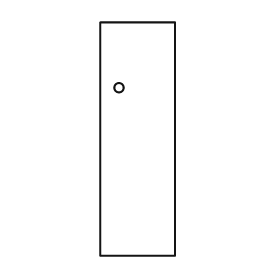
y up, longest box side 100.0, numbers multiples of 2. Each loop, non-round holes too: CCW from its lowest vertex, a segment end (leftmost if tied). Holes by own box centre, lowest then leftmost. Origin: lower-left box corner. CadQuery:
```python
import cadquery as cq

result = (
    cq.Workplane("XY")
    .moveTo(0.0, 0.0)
    .lineTo(32.0, 0.0)
    .lineTo(32.0, 100.0)
    .lineTo(0.0, 100.0)
    .close()
    .moveTo(8.0, 72.0)
    .circle(2.0)
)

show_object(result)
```